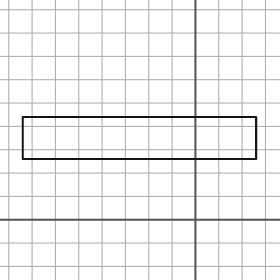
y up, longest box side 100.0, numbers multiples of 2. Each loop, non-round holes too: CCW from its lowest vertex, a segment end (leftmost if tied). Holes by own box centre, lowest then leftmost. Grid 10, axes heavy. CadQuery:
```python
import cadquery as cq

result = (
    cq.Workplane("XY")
    .moveTo(-74.0, 26.0)
    .lineTo(26.0, 26.0)
    .lineTo(26.0, 44.0)
    .lineTo(-74.0, 44.0)
    .close()
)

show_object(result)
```